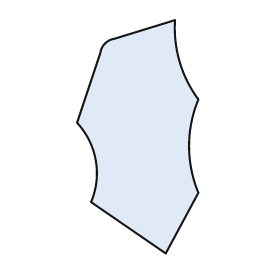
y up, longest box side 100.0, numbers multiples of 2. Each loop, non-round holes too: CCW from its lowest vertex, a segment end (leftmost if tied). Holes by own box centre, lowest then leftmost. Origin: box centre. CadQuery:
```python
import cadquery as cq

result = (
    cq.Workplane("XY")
    .moveTo(12.0, -50.0)
    .lineTo(26.0, -24.0)
    .threePointArc((22.0, -4.0), (26.0, 16.0))
    .threePointArc((18.0, 32.0), (16.0, 50.0))
    .lineTo(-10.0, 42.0)
    .threePointArc((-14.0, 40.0), (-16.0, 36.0))
    .lineTo(-26.0, 6.0)
    .threePointArc((-18.0, -10.0), (-20.0, -28.0))
    .close()
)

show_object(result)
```